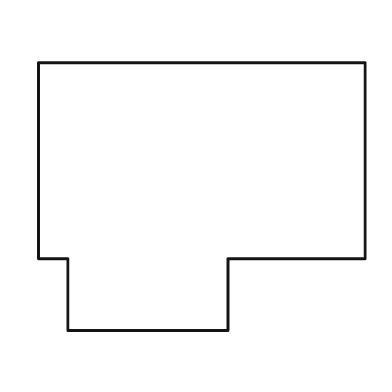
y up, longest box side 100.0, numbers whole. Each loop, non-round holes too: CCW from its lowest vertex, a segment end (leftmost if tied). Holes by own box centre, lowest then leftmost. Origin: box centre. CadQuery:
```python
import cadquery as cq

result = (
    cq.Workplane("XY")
    .moveTo(-41.0, -41.0)
    .lineTo(8.0, -41.0)
    .lineTo(8.0, -19.0)
    .lineTo(50.0, -19.0)
    .lineTo(50.0, 41.0)
    .lineTo(-50.0, 41.0)
    .lineTo(-50.0, -19.0)
    .lineTo(-41.0, -19.0)
    .close()
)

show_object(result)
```